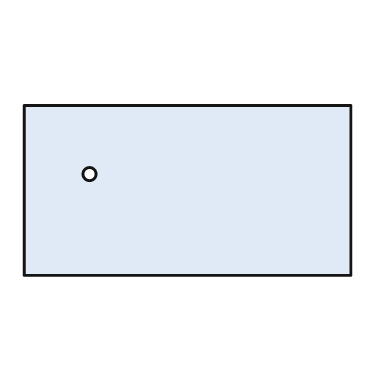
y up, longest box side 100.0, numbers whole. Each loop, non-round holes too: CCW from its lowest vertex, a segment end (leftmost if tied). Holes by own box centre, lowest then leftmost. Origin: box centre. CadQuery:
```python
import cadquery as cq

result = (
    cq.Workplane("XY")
    .moveTo(-50.0, -26.0)
    .lineTo(50.0, -26.0)
    .lineTo(50.0, 26.0)
    .lineTo(-50.0, 26.0)
    .close()
    .moveTo(-30.0, 5.0)
    .circle(2.0)
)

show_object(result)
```